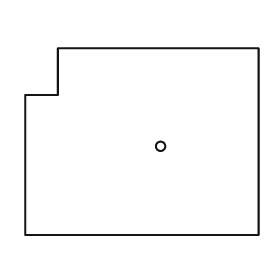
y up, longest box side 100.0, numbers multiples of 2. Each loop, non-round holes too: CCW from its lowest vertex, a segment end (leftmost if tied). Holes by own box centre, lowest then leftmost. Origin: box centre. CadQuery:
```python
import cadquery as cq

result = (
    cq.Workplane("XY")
    .moveTo(-50.0, -40.0)
    .lineTo(50.0, -40.0)
    .lineTo(50.0, 40.0)
    .lineTo(-36.0, 40.0)
    .lineTo(-36.0, 20.0)
    .lineTo(-50.0, 20.0)
    .close()
    .moveTo(8.0, -2.0)
    .circle(2.0)
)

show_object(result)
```